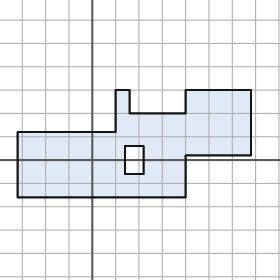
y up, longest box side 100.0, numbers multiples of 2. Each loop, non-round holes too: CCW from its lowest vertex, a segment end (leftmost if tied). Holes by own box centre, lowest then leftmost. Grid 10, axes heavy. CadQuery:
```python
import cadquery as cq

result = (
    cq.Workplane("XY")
    .moveTo(-32.0, -16.0)
    .lineTo(40.0, -16.0)
    .lineTo(40.0, 2.0)
    .lineTo(68.0, 2.0)
    .lineTo(68.0, 30.0)
    .lineTo(40.0, 30.0)
    .lineTo(40.0, 20.0)
    .lineTo(16.0, 20.0)
    .lineTo(16.0, 30.0)
    .lineTo(10.0, 30.0)
    .lineTo(10.0, 12.0)
    .lineTo(-32.0, 12.0)
    .close()
    .moveTo(14.0, -6.0)
    .lineTo(22.0, -6.0)
    .lineTo(22.0, 6.0)
    .lineTo(14.0, 6.0)
    .close()
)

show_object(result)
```